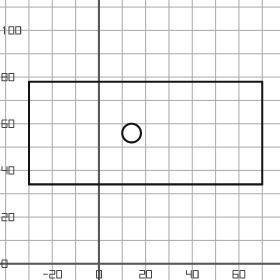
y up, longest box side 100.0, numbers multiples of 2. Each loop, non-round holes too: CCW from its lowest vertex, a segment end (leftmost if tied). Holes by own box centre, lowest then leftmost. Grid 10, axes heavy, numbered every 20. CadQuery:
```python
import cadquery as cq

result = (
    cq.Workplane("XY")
    .moveTo(-30.0, 34.0)
    .lineTo(70.0, 34.0)
    .lineTo(70.0, 78.0)
    .lineTo(-30.0, 78.0)
    .close()
    .moveTo(14.0, 56.0)
    .circle(4.0)
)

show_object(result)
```